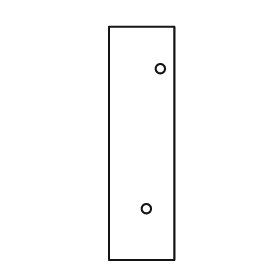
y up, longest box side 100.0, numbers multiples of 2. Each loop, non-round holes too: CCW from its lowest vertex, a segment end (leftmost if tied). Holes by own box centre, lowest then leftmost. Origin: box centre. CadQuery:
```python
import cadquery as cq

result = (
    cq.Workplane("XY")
    .moveTo(-14.0, -50.0)
    .lineTo(14.0, -50.0)
    .lineTo(14.0, 50.0)
    .lineTo(-14.0, 50.0)
    .close()
    .moveTo(2.0, -28.0)
    .circle(2.0)
    .moveTo(8.0, 32.0)
    .circle(2.0)
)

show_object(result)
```